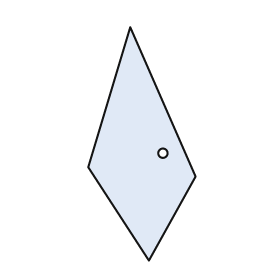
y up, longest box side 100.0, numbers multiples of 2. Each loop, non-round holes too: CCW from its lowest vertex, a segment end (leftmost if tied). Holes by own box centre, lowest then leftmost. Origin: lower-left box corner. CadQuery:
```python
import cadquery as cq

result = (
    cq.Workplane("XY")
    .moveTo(26.0, 0.0)
    .lineTo(46.0, 36.0)
    .lineTo(18.0, 100.0)
    .lineTo(0.0, 40.0)
    .close()
    .moveTo(32.0, 46.0)
    .circle(2.0)
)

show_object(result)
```